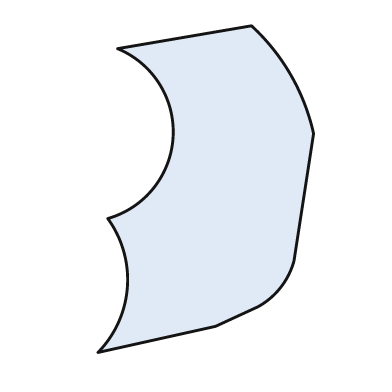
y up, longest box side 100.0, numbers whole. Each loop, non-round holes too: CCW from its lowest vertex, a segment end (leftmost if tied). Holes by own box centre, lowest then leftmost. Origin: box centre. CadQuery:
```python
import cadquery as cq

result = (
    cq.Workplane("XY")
    .moveTo(-33.0, -50.0)
    .lineTo(3.0, -42.0)
    .lineTo(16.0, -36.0)
    .threePointArc((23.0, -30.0), (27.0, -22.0))
    .lineTo(33.0, 17.0)
    .threePointArc((26.0, 35.0), (14.0, 50.0))
    .lineTo(-27.0, 43.0)
    .threePointArc((-10.0, 16.0), (-30.0, -9.0))
    .threePointArc((-24.0, -30.0), (-33.0, -50.0))
    .close()
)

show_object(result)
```